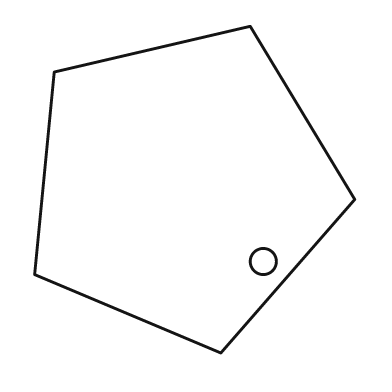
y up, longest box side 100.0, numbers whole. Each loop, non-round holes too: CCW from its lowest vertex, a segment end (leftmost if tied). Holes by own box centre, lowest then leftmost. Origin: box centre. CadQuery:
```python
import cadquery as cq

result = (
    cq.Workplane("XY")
    .moveTo(8.0, -50.0)
    .lineTo(49.0, -3.0)
    .lineTo(17.0, 50.0)
    .lineTo(-43.0, 36.0)
    .lineTo(-49.0, -26.0)
    .close()
    .moveTo(21.0, -22.0)
    .circle(4.0)
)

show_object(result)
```